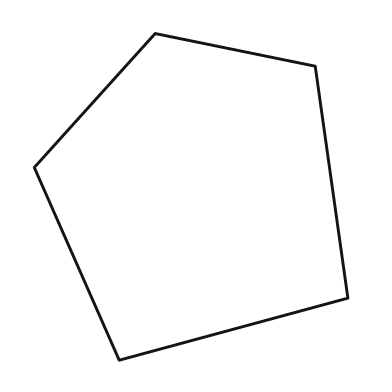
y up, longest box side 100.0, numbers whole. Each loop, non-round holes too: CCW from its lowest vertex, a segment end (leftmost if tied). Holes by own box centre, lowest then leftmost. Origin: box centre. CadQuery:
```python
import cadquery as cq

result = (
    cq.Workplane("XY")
    .moveTo(-22.0, -50.0)
    .lineTo(48.0, -31.0)
    .lineTo(38.0, 40.0)
    .lineTo(-11.0, 50.0)
    .lineTo(-48.0, 9.0)
    .close()
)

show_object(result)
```